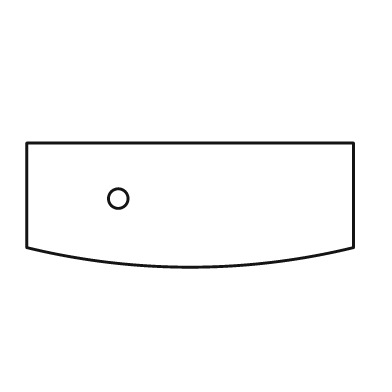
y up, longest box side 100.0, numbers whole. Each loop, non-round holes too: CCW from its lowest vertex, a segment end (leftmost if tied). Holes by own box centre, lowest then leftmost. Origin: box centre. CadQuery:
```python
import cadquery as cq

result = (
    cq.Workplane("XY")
    .moveTo(-50.0, -13.0)
    .threePointArc((0.0, -19.0), (50.0, -13.0))
    .lineTo(50.0, 19.0)
    .lineTo(-50.0, 19.0)
    .close()
    .moveTo(-22.0, 2.0)
    .circle(3.0)
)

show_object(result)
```